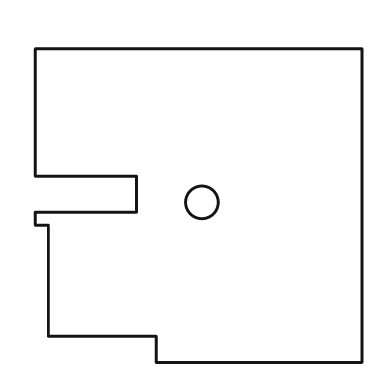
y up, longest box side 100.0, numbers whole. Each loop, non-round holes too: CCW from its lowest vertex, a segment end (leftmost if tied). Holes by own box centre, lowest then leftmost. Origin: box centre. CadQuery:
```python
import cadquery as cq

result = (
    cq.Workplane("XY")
    .moveTo(-13.0, -48.0)
    .lineTo(50.0, -48.0)
    .lineTo(50.0, 48.0)
    .lineTo(-50.0, 48.0)
    .lineTo(-50.0, 9.0)
    .lineTo(-19.0, 9.0)
    .lineTo(-19.0, -2.0)
    .lineTo(-50.0, -2.0)
    .lineTo(-50.0, -6.0)
    .lineTo(-46.0, -6.0)
    .lineTo(-46.0, -40.0)
    .lineTo(-13.0, -40.0)
    .close()
    .moveTo(1.0, 1.0)
    .circle(5.0)
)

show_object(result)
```